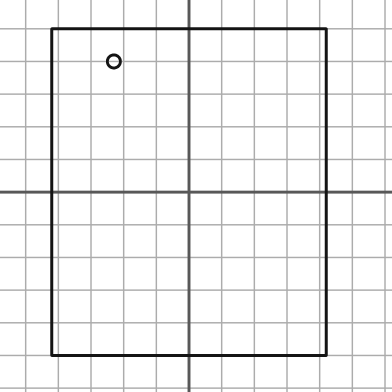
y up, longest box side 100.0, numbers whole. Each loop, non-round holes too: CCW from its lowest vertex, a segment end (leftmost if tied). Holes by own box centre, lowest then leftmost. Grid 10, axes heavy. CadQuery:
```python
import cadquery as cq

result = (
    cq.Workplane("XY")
    .moveTo(-42.0, -50.0)
    .lineTo(42.0, -50.0)
    .lineTo(42.0, 50.0)
    .lineTo(-42.0, 50.0)
    .close()
    .moveTo(-23.0, 40.0)
    .circle(2.0)
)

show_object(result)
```